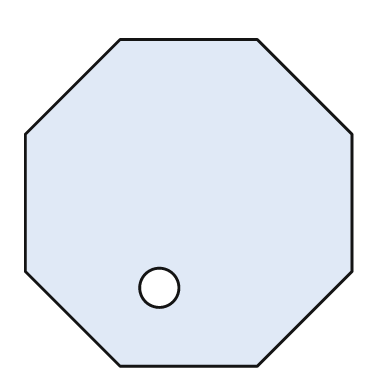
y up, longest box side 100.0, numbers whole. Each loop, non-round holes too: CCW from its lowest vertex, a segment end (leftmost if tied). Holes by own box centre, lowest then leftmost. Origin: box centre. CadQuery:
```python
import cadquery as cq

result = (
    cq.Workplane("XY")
    .moveTo(-21.0, -50.0)
    .lineTo(21.0, -50.0)
    .lineTo(50.0, -21.0)
    .lineTo(50.0, 21.0)
    .lineTo(21.0, 50.0)
    .lineTo(-21.0, 50.0)
    .lineTo(-50.0, 21.0)
    .lineTo(-50.0, -21.0)
    .close()
    .moveTo(-9.0, -26.0)
    .circle(6.0)
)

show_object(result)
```